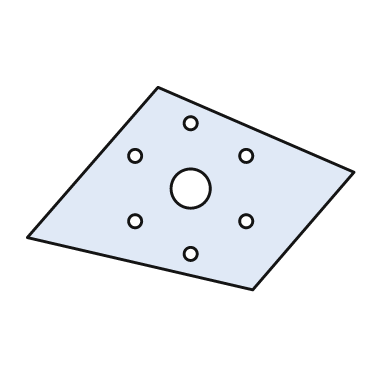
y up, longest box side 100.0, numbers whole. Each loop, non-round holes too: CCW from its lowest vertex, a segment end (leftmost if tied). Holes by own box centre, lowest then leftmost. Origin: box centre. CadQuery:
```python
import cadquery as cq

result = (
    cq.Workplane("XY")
    .moveTo(19.0, -31.0)
    .lineTo(50.0, 5.0)
    .lineTo(-10.0, 31.0)
    .lineTo(-50.0, -15.0)
    .close()
    .moveTo(0.0, -20.0)
    .circle(2.0)
    .moveTo(-17.0, -10.0)
    .circle(2.0)
    .moveTo(17.0, -10.0)
    .circle(2.0)
    .moveTo(0.0, 0.0)
    .circle(6.0)
    .moveTo(-17.0, 10.0)
    .circle(2.0)
    .moveTo(17.0, 10.0)
    .circle(2.0)
    .moveTo(0.0, 20.0)
    .circle(2.0)
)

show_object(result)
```